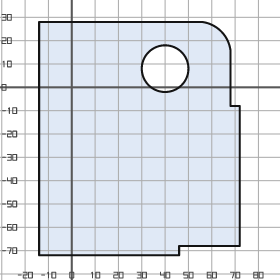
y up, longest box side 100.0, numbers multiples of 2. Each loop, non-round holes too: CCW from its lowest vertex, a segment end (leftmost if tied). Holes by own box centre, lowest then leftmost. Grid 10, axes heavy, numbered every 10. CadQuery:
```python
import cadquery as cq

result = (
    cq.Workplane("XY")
    .moveTo(-14.0, -72.0)
    .lineTo(46.0, -72.0)
    .lineTo(46.0, -68.0)
    .lineTo(72.0, -68.0)
    .lineTo(72.0, -8.0)
    .lineTo(68.0, -8.0)
    .lineTo(68.0, 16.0)
    .threePointArc((64.0, 24.0), (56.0, 28.0))
    .lineTo(-14.0, 28.0)
    .close()
    .moveTo(40.0, 8.0)
    .circle(10.0)
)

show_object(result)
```